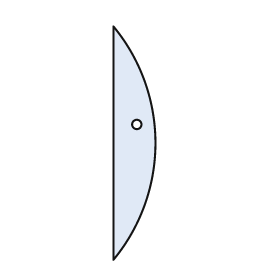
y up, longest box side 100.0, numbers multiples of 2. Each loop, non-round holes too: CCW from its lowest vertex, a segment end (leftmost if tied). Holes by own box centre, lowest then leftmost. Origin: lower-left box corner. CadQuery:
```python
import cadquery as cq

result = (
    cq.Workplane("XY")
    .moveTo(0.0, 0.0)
    .threePointArc((18.0, 50.0), (0.0, 100.0))
    .close()
    .moveTo(10.0, 58.0)
    .circle(2.0)
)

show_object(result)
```